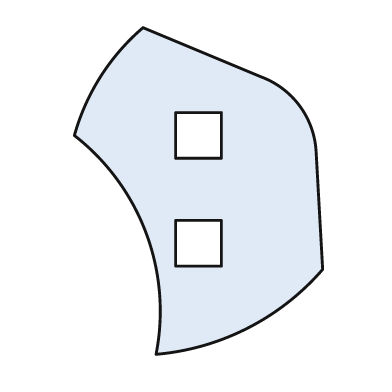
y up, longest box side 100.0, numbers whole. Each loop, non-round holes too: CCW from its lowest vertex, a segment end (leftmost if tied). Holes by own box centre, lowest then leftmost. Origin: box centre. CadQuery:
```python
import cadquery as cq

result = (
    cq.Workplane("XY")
    .moveTo(-13.0, -50.0)
    .threePointArc((15.0, -42.0), (38.0, -24.0))
    .lineTo(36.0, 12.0)
    .threePointArc((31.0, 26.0), (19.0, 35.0))
    .lineTo(-17.0, 50.0)
    .threePointArc((-30.0, 35.0), (-38.0, 17.0))
    .threePointArc((-16.0, -13.0), (-13.0, -50.0))
    .close()
    .moveTo(-7.0, -23.0)
    .lineTo(7.0, -23.0)
    .lineTo(7.0, -9.0)
    .lineTo(-7.0, -9.0)
    .close()
    .moveTo(-7.0, 10.0)
    .lineTo(7.0, 10.0)
    .lineTo(7.0, 24.0)
    .lineTo(-7.0, 24.0)
    .close()
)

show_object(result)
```